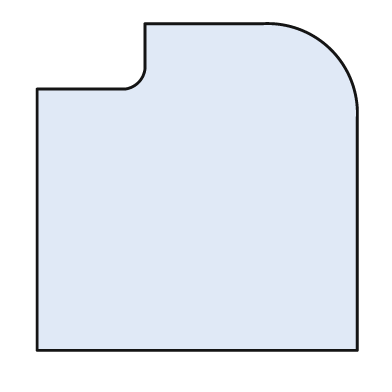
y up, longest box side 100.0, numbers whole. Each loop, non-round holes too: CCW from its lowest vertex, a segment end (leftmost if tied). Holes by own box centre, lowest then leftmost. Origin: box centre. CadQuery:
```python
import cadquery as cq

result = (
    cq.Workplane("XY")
    .moveTo(-49.0, -50.0)
    .lineTo(49.0, -50.0)
    .lineTo(49.0, 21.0)
    .threePointArc((41.0, 42.0), (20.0, 50.0))
    .lineTo(-16.0, 50.0)
    .lineTo(-16.0, 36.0)
    .threePointArc((-18.0, 32.0), (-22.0, 30.0))
    .lineTo(-49.0, 30.0)
    .close()
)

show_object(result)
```